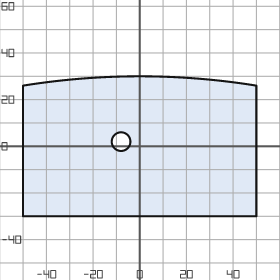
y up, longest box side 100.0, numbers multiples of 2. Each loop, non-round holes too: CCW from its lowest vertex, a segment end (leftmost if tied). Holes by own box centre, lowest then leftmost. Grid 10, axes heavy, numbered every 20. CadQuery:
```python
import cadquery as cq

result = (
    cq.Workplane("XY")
    .moveTo(-50.0, -30.0)
    .lineTo(50.0, -30.0)
    .lineTo(50.0, 26.0)
    .threePointArc((0.0, 30.0), (-50.0, 26.0))
    .close()
    .moveTo(-8.0, 2.0)
    .circle(4.0)
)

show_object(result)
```